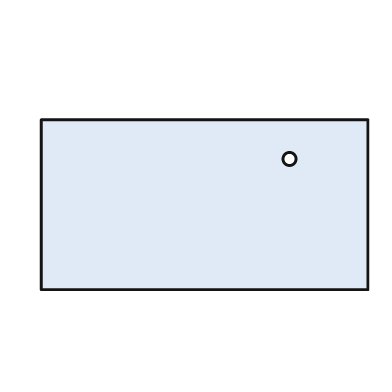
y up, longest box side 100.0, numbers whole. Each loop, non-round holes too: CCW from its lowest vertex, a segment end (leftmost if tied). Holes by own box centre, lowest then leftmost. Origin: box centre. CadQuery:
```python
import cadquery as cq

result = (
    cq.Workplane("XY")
    .moveTo(-50.0, -26.0)
    .lineTo(50.0, -26.0)
    .lineTo(50.0, 26.0)
    .lineTo(-50.0, 26.0)
    .close()
    .moveTo(26.0, 14.0)
    .circle(2.0)
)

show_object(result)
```